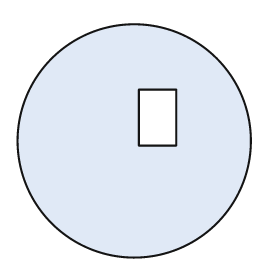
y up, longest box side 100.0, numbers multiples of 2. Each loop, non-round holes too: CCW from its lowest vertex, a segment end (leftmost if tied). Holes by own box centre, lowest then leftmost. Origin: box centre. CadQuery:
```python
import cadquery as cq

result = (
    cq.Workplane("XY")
    .moveTo(0.0, 0.0)
    .circle(50.0)
    .moveTo(2.0, -2.0)
    .lineTo(18.0, -2.0)
    .lineTo(18.0, 22.0)
    .lineTo(2.0, 22.0)
    .close()
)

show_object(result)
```